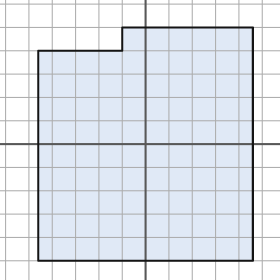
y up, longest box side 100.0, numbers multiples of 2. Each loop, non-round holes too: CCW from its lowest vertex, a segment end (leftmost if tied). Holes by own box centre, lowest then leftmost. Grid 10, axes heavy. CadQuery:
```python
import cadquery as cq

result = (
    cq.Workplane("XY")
    .moveTo(-46.0, -50.0)
    .lineTo(46.0, -50.0)
    .lineTo(46.0, 50.0)
    .lineTo(-10.0, 50.0)
    .lineTo(-10.0, 40.0)
    .lineTo(-46.0, 40.0)
    .close()
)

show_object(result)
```